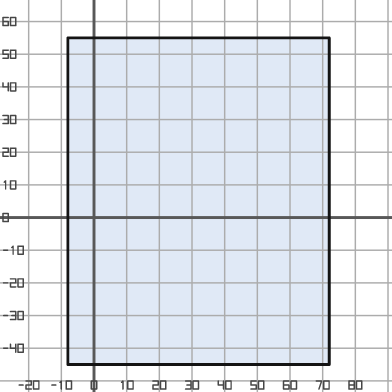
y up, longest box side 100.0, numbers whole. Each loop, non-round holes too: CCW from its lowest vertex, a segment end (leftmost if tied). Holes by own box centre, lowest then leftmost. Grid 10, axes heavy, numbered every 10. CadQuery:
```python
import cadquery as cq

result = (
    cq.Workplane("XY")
    .moveTo(-8.0, -45.0)
    .lineTo(72.0, -45.0)
    .lineTo(72.0, 55.0)
    .lineTo(-8.0, 55.0)
    .close()
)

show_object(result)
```